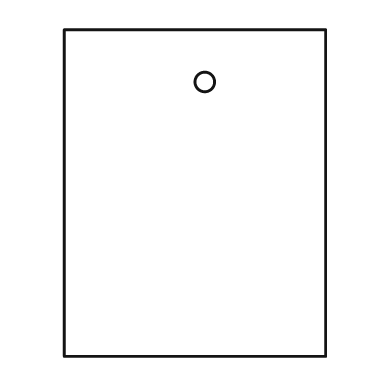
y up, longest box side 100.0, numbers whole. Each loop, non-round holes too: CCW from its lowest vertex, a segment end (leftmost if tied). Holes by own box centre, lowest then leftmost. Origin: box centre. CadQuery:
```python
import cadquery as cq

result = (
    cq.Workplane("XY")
    .moveTo(-40.0, -50.0)
    .lineTo(40.0, -50.0)
    .lineTo(40.0, 50.0)
    .lineTo(-40.0, 50.0)
    .close()
    .moveTo(3.0, 34.0)
    .circle(3.0)
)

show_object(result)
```